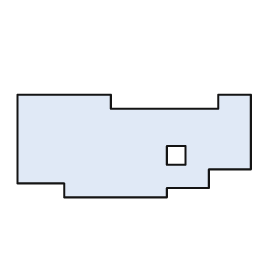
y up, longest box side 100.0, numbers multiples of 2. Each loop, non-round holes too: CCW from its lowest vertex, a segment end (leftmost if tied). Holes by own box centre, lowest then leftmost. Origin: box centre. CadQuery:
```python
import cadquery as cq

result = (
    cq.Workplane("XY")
    .moveTo(-30.0, -22.0)
    .lineTo(14.0, -22.0)
    .lineTo(14.0, -18.0)
    .lineTo(32.0, -18.0)
    .lineTo(32.0, -10.0)
    .lineTo(50.0, -10.0)
    .lineTo(50.0, 22.0)
    .lineTo(36.0, 22.0)
    .lineTo(36.0, 16.0)
    .lineTo(-10.0, 16.0)
    .lineTo(-10.0, 22.0)
    .lineTo(-50.0, 22.0)
    .lineTo(-50.0, -16.0)
    .lineTo(-30.0, -16.0)
    .close()
    .moveTo(14.0, -8.0)
    .lineTo(22.0, -8.0)
    .lineTo(22.0, 0.0)
    .lineTo(14.0, 0.0)
    .close()
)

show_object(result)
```